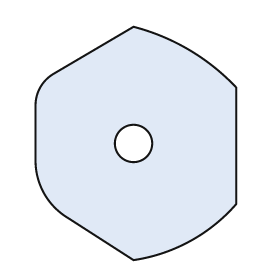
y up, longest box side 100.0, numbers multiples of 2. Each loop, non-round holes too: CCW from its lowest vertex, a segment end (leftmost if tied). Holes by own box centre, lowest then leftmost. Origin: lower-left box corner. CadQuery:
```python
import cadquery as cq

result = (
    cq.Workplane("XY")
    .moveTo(42.0, 0.0)
    .threePointArc((66.0, 8.0), (86.0, 24.0))
    .lineTo(86.0, 74.0)
    .threePointArc((66.0, 90.0), (42.0, 100.0))
    .lineTo(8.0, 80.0)
    .threePointArc((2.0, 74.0), (0.0, 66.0))
    .lineTo(0.0, 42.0)
    .threePointArc((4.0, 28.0), (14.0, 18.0))
    .close()
    .moveTo(42.0, 50.0)
    .circle(8.0)
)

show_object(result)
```